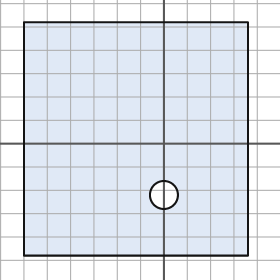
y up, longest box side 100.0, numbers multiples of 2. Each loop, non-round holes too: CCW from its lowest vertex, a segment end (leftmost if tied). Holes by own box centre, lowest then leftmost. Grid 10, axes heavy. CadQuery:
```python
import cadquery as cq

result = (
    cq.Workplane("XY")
    .moveTo(-60.0, -48.0)
    .lineTo(36.0, -48.0)
    .lineTo(36.0, 52.0)
    .lineTo(-60.0, 52.0)
    .close()
    .moveTo(0.0, -22.0)
    .circle(6.0)
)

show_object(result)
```